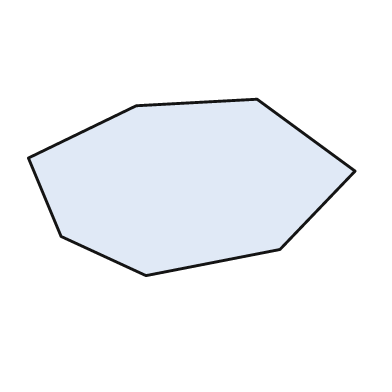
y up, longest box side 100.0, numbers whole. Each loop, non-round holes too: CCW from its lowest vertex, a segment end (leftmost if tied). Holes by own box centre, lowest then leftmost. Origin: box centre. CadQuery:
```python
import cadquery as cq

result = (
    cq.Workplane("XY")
    .moveTo(-14.0, -27.0)
    .lineTo(27.0, -19.0)
    .lineTo(50.0, 5.0)
    .lineTo(20.0, 27.0)
    .lineTo(-17.0, 25.0)
    .lineTo(-50.0, 9.0)
    .lineTo(-40.0, -15.0)
    .close()
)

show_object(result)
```